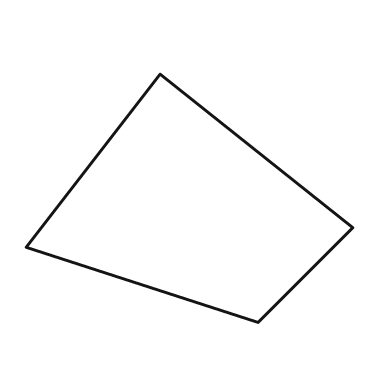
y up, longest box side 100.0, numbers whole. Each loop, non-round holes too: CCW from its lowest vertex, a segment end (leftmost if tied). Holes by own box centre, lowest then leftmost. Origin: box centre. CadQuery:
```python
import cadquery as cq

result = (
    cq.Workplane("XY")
    .moveTo(21.0, -38.0)
    .lineTo(50.0, -9.0)
    .lineTo(-9.0, 38.0)
    .lineTo(-50.0, -15.0)
    .close()
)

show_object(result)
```